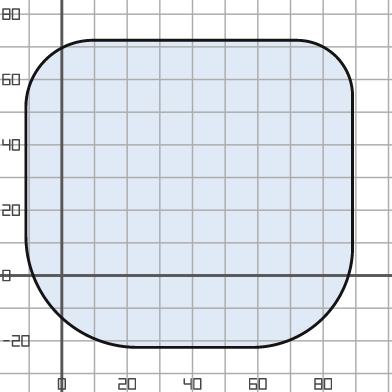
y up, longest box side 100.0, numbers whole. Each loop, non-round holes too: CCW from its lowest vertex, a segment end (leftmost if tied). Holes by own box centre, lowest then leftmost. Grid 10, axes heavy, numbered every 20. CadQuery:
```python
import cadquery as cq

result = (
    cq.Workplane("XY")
    .moveTo(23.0, -22.0)
    .lineTo(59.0, -22.0)
    .threePointArc((80.0, -13.0), (89.0, 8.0))
    .lineTo(89.0, 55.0)
    .threePointArc((84.0, 67.0), (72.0, 72.0))
    .lineTo(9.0, 72.0)
    .threePointArc((-5.0, 66.0), (-11.0, 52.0))
    .lineTo(-11.0, 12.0)
    .threePointArc((-1.0, -12.0), (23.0, -22.0))
    .close()
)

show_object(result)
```